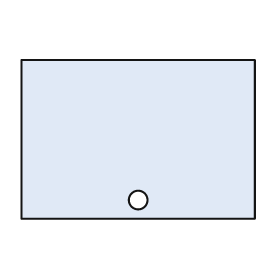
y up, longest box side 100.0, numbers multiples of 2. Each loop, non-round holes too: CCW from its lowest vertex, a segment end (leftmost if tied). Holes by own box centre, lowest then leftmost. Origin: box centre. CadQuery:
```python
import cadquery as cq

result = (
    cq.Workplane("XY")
    .moveTo(-50.0, -34.0)
    .lineTo(50.0, -34.0)
    .lineTo(50.0, 34.0)
    .lineTo(-50.0, 34.0)
    .close()
    .moveTo(0.0, -26.0)
    .circle(4.0)
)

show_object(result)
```